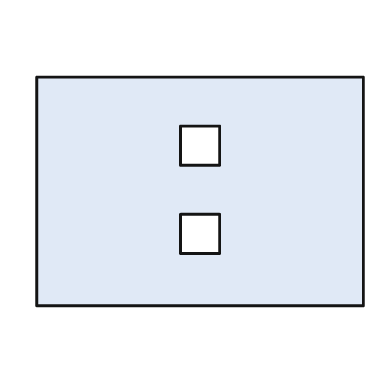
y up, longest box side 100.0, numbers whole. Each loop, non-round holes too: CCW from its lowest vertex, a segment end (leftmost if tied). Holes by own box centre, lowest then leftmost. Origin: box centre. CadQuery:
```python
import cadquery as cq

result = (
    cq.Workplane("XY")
    .moveTo(-50.0, -35.0)
    .lineTo(50.0, -35.0)
    .lineTo(50.0, 35.0)
    .lineTo(-50.0, 35.0)
    .close()
    .moveTo(-6.0, -19.0)
    .lineTo(6.0, -19.0)
    .lineTo(6.0, -7.0)
    .lineTo(-6.0, -7.0)
    .close()
    .moveTo(-6.0, 8.0)
    .lineTo(6.0, 8.0)
    .lineTo(6.0, 20.0)
    .lineTo(-6.0, 20.0)
    .close()
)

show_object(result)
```